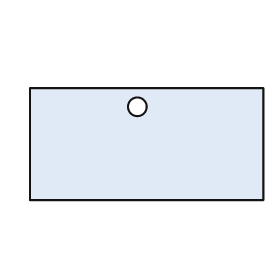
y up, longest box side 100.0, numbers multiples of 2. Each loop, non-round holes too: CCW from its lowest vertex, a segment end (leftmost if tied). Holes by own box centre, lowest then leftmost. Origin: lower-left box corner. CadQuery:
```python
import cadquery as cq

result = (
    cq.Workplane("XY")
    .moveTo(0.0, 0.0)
    .lineTo(100.0, 0.0)
    .lineTo(100.0, 48.0)
    .lineTo(0.0, 48.0)
    .close()
    .moveTo(46.0, 40.0)
    .circle(4.0)
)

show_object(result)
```